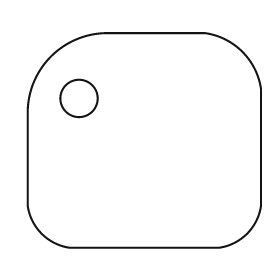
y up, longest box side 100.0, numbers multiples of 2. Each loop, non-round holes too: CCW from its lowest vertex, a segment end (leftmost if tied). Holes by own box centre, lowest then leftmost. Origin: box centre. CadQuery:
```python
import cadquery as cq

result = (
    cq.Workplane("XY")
    .moveTo(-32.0, -46.0)
    .lineTo(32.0, -46.0)
    .threePointArc((44.0, -40.0), (50.0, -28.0))
    .lineTo(50.0, 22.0)
    .threePointArc((42.0, 38.0), (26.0, 46.0))
    .lineTo(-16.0, 46.0)
    .threePointArc((-40.0, 36.0), (-50.0, 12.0))
    .lineTo(-50.0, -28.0)
    .threePointArc((-44.0, -40.0), (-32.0, -46.0))
    .close()
    .moveTo(-28.0, 18.0)
    .circle(8.0)
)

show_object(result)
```